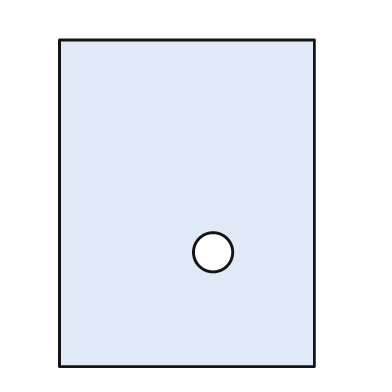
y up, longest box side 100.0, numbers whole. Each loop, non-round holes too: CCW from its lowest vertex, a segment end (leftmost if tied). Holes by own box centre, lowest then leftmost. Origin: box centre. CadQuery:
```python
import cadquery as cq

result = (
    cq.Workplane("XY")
    .moveTo(-39.0, -50.0)
    .lineTo(39.0, -50.0)
    .lineTo(39.0, 50.0)
    .lineTo(-39.0, 50.0)
    .close()
    .moveTo(8.0, -15.0)
    .circle(6.0)
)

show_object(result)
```